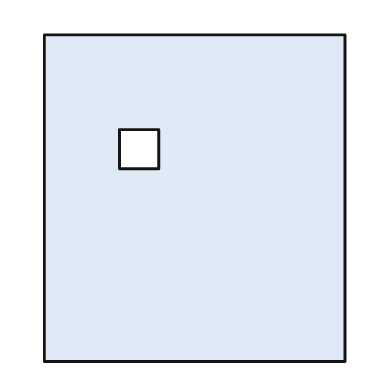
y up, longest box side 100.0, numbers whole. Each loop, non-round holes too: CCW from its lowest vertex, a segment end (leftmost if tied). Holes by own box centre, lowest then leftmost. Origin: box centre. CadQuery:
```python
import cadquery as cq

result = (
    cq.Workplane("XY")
    .moveTo(-46.0, -50.0)
    .lineTo(46.0, -50.0)
    .lineTo(46.0, 50.0)
    .lineTo(-46.0, 50.0)
    .close()
    .moveTo(-23.0, 9.0)
    .lineTo(-11.0, 9.0)
    .lineTo(-11.0, 21.0)
    .lineTo(-23.0, 21.0)
    .close()
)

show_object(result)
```